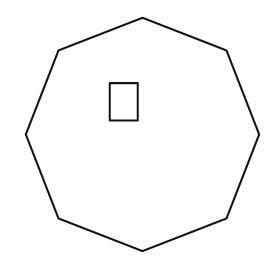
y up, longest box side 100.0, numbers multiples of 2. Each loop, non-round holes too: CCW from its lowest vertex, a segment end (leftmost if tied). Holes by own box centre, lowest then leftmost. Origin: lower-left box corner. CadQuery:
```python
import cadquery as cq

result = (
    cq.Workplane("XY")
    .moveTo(50.0, 0.0)
    .lineTo(86.0, 14.0)
    .lineTo(100.0, 50.0)
    .lineTo(86.0, 86.0)
    .lineTo(50.0, 100.0)
    .lineTo(14.0, 86.0)
    .lineTo(0.0, 50.0)
    .lineTo(14.0, 14.0)
    .close()
    .moveTo(36.0, 56.0)
    .lineTo(48.0, 56.0)
    .lineTo(48.0, 72.0)
    .lineTo(36.0, 72.0)
    .close()
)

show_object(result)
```